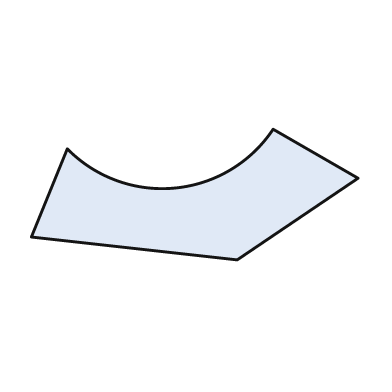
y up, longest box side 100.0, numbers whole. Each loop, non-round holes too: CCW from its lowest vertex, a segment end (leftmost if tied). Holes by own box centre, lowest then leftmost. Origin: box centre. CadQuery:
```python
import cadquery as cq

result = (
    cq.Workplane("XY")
    .moveTo(13.0, -20.0)
    .lineTo(50.0, 5.0)
    .lineTo(24.0, 20.0)
    .threePointArc((-6.0, 2.0), (-39.0, 14.0))
    .lineTo(-50.0, -13.0)
    .close()
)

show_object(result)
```